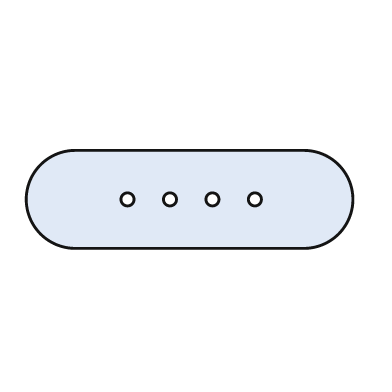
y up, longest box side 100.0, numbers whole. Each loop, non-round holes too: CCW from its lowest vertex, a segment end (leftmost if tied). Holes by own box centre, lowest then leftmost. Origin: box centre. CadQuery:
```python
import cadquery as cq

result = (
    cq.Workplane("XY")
    .moveTo(-35.0, -15.0)
    .lineTo(35.0, -15.0)
    .threePointArc((50.0, 0.0), (35.0, 15.0))
    .lineTo(-35.0, 15.0)
    .threePointArc((-50.0, 0.0), (-35.0, -15.0))
    .close()
    .moveTo(-19.0, 0.0)
    .circle(2.0)
    .moveTo(-6.0, 0.0)
    .circle(2.0)
    .moveTo(7.0, 0.0)
    .circle(2.0)
    .moveTo(20.0, 0.0)
    .circle(2.0)
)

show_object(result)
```